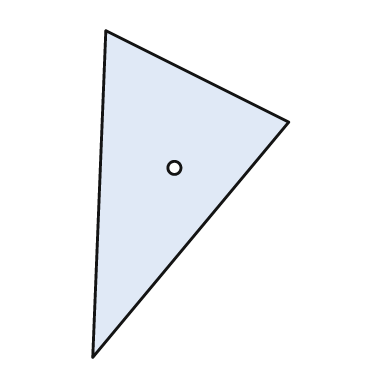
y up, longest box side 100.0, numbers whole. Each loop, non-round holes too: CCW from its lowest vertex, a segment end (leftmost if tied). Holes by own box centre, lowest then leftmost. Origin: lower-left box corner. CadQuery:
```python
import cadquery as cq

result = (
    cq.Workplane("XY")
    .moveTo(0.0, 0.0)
    .lineTo(60.0, 72.0)
    .lineTo(4.0, 100.0)
    .close()
    .moveTo(25.0, 58.0)
    .circle(2.0)
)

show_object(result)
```